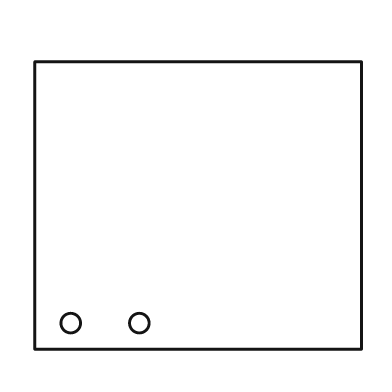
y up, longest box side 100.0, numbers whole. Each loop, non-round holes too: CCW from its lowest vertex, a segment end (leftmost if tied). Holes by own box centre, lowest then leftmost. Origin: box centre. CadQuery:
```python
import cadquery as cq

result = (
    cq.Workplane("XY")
    .moveTo(-50.0, -44.0)
    .lineTo(50.0, -44.0)
    .lineTo(50.0, 44.0)
    .lineTo(-50.0, 44.0)
    .close()
    .moveTo(-39.0, -36.0)
    .circle(3.0)
    .moveTo(-18.0, -36.0)
    .circle(3.0)
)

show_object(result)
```